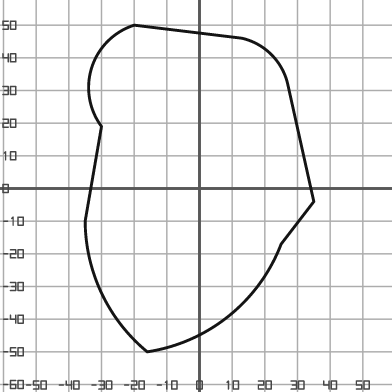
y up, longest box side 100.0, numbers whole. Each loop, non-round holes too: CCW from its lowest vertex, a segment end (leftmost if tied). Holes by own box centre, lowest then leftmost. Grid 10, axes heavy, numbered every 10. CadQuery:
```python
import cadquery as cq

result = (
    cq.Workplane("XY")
    .moveTo(-16.0, -50.0)
    .threePointArc((9.0, -39.0), (25.0, -17.0))
    .lineTo(35.0, -4.0)
    .lineTo(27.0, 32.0)
    .threePointArc((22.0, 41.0), (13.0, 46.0))
    .lineTo(-20.0, 50.0)
    .threePointArc((-33.0, 37.0), (-30.0, 19.0))
    .lineTo(-35.0, -10.0)
    .threePointArc((-30.0, -32.0), (-16.0, -50.0))
    .close()
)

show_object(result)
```